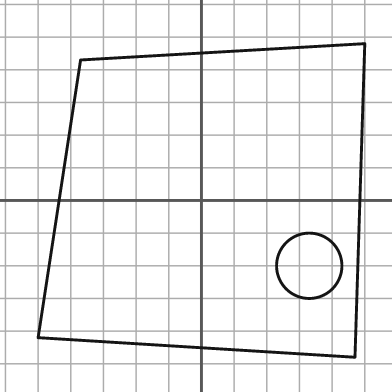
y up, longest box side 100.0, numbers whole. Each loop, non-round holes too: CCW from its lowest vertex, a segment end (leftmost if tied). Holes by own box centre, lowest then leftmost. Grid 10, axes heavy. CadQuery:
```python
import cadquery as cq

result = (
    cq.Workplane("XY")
    .moveTo(47.0, -48.0)
    .lineTo(50.0, 48.0)
    .lineTo(-37.0, 43.0)
    .lineTo(-50.0, -42.0)
    .close()
    .moveTo(33.0, -20.0)
    .circle(10.0)
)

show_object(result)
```